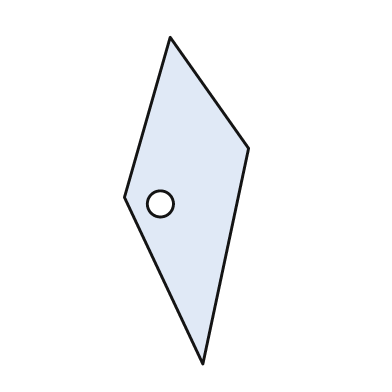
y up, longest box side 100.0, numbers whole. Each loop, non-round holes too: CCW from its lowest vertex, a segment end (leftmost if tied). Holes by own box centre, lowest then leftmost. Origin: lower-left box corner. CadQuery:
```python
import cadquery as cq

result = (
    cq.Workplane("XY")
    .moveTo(24.0, 0.0)
    .lineTo(38.0, 66.0)
    .lineTo(14.0, 100.0)
    .lineTo(0.0, 51.0)
    .close()
    .moveTo(11.0, 49.0)
    .circle(4.0)
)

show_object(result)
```